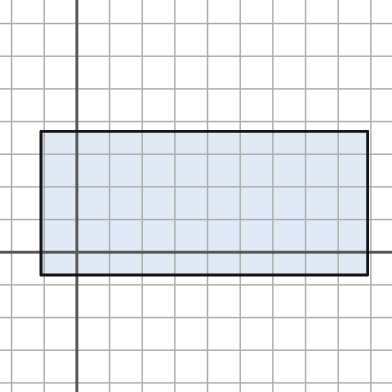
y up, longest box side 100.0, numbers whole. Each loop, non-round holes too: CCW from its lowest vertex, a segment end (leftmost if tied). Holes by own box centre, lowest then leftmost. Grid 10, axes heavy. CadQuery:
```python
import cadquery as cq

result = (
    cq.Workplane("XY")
    .moveTo(-11.0, -7.0)
    .lineTo(89.0, -7.0)
    .lineTo(89.0, 37.0)
    .lineTo(-11.0, 37.0)
    .close()
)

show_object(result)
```